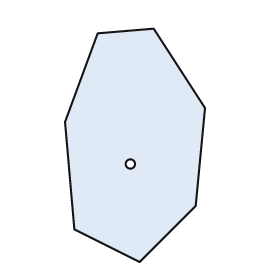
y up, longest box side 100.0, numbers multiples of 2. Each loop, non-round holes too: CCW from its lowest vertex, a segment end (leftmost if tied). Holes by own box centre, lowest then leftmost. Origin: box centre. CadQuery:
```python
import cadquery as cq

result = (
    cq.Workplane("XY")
    .moveTo(2.0, -50.0)
    .lineTo(26.0, -26.0)
    .lineTo(30.0, 16.0)
    .lineTo(8.0, 50.0)
    .lineTo(-16.0, 48.0)
    .lineTo(-30.0, 10.0)
    .lineTo(-26.0, -36.0)
    .close()
    .moveTo(-2.0, -8.0)
    .circle(2.0)
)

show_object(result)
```